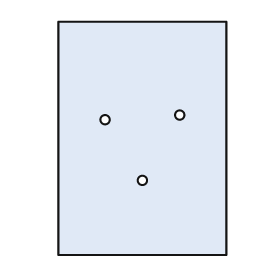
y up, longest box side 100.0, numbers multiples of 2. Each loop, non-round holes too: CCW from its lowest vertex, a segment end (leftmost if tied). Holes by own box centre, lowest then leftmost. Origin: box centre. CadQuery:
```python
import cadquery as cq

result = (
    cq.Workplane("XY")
    .moveTo(-36.0, -50.0)
    .lineTo(36.0, -50.0)
    .lineTo(36.0, 50.0)
    .lineTo(-36.0, 50.0)
    .close()
    .moveTo(0.0, -18.0)
    .circle(2.0)
    .moveTo(-16.0, 8.0)
    .circle(2.0)
    .moveTo(16.0, 10.0)
    .circle(2.0)
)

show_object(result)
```